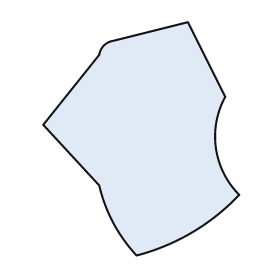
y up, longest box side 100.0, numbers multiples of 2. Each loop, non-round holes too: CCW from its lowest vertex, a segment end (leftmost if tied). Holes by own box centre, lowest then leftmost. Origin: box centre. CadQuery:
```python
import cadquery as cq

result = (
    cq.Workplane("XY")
    .moveTo(-2.0, -50.0)
    .threePointArc((22.0, -40.0), (42.0, -24.0))
    .threePointArc((32.0, -4.0), (36.0, 18.0))
    .lineTo(20.0, 50.0)
    .lineTo(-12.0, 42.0)
    .threePointArc((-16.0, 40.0), (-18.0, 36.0))
    .lineTo(-42.0, 6.0)
    .lineTo(-18.0, -20.0)
    .threePointArc((-12.0, -36.0), (-2.0, -50.0))
    .close()
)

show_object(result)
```